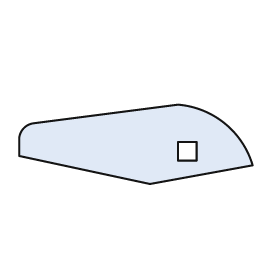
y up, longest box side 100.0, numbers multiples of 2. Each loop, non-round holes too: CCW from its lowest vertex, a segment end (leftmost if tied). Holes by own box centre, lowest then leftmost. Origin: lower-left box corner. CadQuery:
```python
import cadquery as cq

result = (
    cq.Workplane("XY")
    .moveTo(56.0, 0.0)
    .lineTo(100.0, 8.0)
    .threePointArc((88.0, 26.0), (68.0, 34.0))
    .lineTo(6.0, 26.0)
    .threePointArc((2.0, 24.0), (0.0, 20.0))
    .lineTo(0.0, 12.0)
    .close()
    .moveTo(68.0, 10.0)
    .lineTo(76.0, 10.0)
    .lineTo(76.0, 18.0)
    .lineTo(68.0, 18.0)
    .close()
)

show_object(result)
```